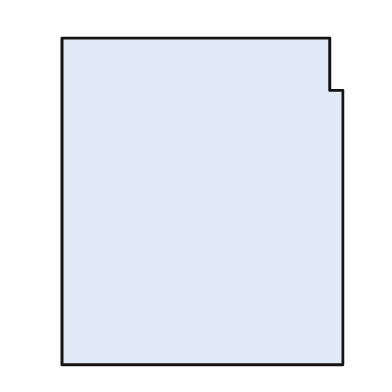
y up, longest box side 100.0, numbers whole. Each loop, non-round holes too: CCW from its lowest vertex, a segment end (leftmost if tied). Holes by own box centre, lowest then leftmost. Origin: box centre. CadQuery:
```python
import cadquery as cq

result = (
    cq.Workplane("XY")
    .moveTo(-43.0, -50.0)
    .lineTo(43.0, -50.0)
    .lineTo(43.0, 34.0)
    .lineTo(39.0, 34.0)
    .lineTo(39.0, 50.0)
    .lineTo(-43.0, 50.0)
    .close()
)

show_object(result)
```